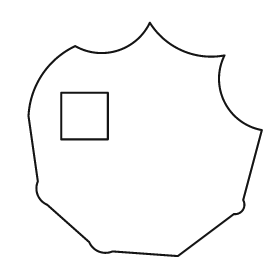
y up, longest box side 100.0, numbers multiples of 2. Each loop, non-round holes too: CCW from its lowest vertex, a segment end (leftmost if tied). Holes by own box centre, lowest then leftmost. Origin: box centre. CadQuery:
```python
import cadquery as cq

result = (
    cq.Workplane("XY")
    .moveTo(14.0, -50.0)
    .lineTo(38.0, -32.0)
    .threePointArc((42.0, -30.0), (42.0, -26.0))
    .lineTo(50.0, 4.0)
    .threePointArc((34.0, 16.0), (34.0, 36.0))
    .threePointArc((16.0, 38.0), (2.0, 50.0))
    .threePointArc((-12.0, 38.0), (-30.0, 40.0))
    .threePointArc((-44.0, 28.0), (-50.0, 10.0))
    .lineTo(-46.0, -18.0)
    .threePointArc((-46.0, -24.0), (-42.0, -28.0))
    .lineTo(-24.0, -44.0)
    .threePointArc((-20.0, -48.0), (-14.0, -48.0))
    .close()
    .moveTo(-36.0, 0.0)
    .lineTo(-16.0, 0.0)
    .lineTo(-16.0, 20.0)
    .lineTo(-36.0, 20.0)
    .close()
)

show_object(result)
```